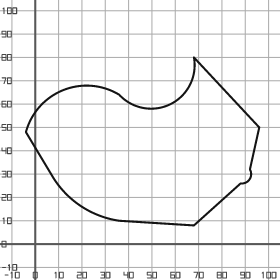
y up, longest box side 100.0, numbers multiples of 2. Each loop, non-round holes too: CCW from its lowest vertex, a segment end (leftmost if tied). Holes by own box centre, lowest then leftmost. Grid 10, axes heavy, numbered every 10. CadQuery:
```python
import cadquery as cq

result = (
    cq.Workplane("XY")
    .moveTo(68.0, 8.0)
    .lineTo(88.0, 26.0)
    .threePointArc((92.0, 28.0), (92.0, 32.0))
    .lineTo(96.0, 50.0)
    .lineTo(68.0, 80.0)
    .threePointArc((58.0, 60.0), (36.0, 64.0))
    .threePointArc((12.0, 66.0), (-4.0, 48.0))
    .lineTo(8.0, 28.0)
    .threePointArc((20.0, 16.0), (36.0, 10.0))
    .close()
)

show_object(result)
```